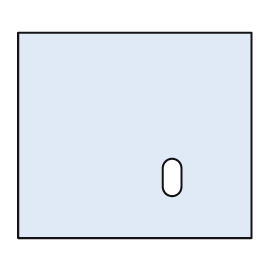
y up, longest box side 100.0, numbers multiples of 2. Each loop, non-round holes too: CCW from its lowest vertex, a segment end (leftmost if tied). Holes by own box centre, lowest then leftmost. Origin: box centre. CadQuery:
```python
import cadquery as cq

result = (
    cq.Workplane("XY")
    .moveTo(-50.0, -44.0)
    .lineTo(50.0, -44.0)
    .lineTo(50.0, 44.0)
    .lineTo(-50.0, 44.0)
    .close()
    .moveTo(12.0, -22.0)
    .threePointArc((16.0, -26.0), (20.0, -22.0))
    .lineTo(20.0, -14.0)
    .threePointArc((16.0, -10.0), (12.0, -14.0))
    .close()
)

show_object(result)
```